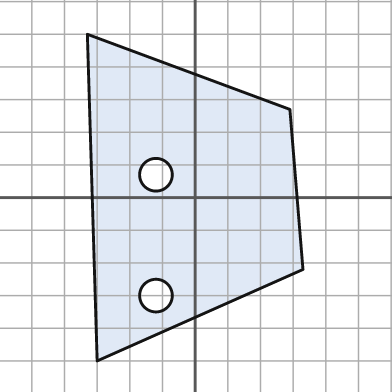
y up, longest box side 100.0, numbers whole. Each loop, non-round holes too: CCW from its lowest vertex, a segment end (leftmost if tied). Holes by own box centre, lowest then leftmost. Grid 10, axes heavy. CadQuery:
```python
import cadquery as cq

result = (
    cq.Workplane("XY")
    .moveTo(-30.0, -50.0)
    .lineTo(33.0, -22.0)
    .lineTo(29.0, 27.0)
    .lineTo(-33.0, 50.0)
    .close()
    .moveTo(-12.0, -30.0)
    .circle(5.0)
    .moveTo(-12.0, 7.0)
    .circle(5.0)
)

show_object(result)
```